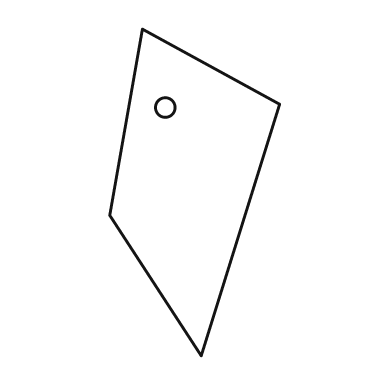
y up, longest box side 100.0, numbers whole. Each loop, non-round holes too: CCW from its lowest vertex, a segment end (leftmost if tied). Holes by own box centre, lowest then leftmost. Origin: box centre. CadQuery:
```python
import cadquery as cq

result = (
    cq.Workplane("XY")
    .moveTo(2.0, -50.0)
    .lineTo(26.0, 27.0)
    .lineTo(-16.0, 50.0)
    .lineTo(-26.0, -7.0)
    .close()
    .moveTo(-9.0, 26.0)
    .circle(3.0)
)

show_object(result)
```